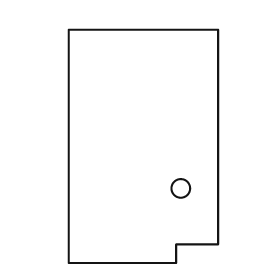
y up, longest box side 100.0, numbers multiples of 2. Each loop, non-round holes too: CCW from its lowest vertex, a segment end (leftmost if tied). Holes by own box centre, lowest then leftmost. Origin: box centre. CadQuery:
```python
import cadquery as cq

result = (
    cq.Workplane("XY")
    .moveTo(-32.0, -50.0)
    .lineTo(14.0, -50.0)
    .lineTo(14.0, -42.0)
    .lineTo(32.0, -42.0)
    .lineTo(32.0, 50.0)
    .lineTo(-32.0, 50.0)
    .close()
    .moveTo(16.0, -18.0)
    .circle(4.0)
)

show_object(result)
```